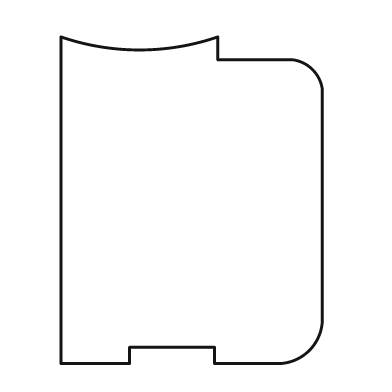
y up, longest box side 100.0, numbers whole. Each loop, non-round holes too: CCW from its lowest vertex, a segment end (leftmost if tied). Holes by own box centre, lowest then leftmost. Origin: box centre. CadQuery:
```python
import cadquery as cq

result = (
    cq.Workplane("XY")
    .moveTo(-40.0, -50.0)
    .lineTo(-19.0, -50.0)
    .lineTo(-19.0, -45.0)
    .lineTo(7.0, -45.0)
    .lineTo(7.0, -50.0)
    .lineTo(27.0, -50.0)
    .threePointArc((36.0, -46.0), (40.0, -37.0))
    .lineTo(40.0, 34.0)
    .threePointArc((37.0, 40.0), (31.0, 43.0))
    .lineTo(8.0, 43.0)
    .lineTo(8.0, 50.0)
    .threePointArc((-16.0, 46.0), (-40.0, 50.0))
    .close()
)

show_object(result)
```